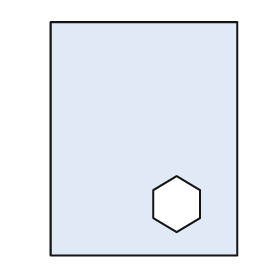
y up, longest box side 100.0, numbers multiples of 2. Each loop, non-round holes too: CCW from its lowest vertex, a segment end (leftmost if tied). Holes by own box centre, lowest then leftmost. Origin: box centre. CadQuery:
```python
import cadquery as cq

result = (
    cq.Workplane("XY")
    .moveTo(-40.0, -50.0)
    .lineTo(40.0, -50.0)
    .lineTo(40.0, 50.0)
    .lineTo(-40.0, 50.0)
    .close()
    .moveTo(14.0, -40.0)
    .lineTo(24.0, -34.0)
    .lineTo(24.0, -22.0)
    .lineTo(14.0, -16.0)
    .lineTo(4.0, -22.0)
    .lineTo(4.0, -34.0)
    .close()
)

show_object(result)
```